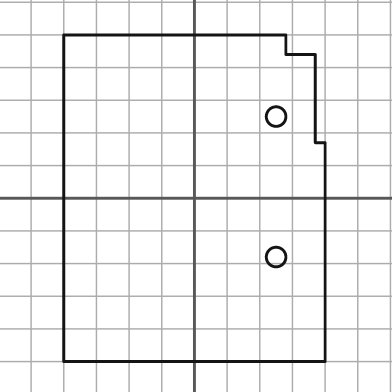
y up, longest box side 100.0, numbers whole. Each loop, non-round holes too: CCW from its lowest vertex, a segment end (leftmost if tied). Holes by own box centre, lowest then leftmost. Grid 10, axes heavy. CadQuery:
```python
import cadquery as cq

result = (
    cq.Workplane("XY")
    .moveTo(-40.0, -50.0)
    .lineTo(40.0, -50.0)
    .lineTo(40.0, 17.0)
    .lineTo(37.0, 17.0)
    .lineTo(37.0, 44.0)
    .lineTo(28.0, 44.0)
    .lineTo(28.0, 50.0)
    .lineTo(-40.0, 50.0)
    .close()
    .moveTo(25.0, -18.0)
    .circle(3.0)
    .moveTo(25.0, 25.0)
    .circle(3.0)
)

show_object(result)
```